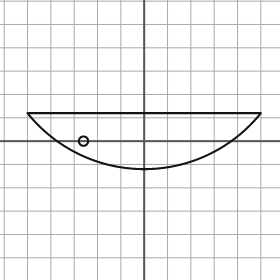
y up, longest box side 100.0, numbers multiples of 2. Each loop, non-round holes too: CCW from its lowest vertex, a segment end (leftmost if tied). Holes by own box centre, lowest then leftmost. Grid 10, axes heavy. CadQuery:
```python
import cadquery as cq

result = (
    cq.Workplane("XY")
    .moveTo(-50.0, 12.0)
    .threePointArc((0.0, -12.0), (50.0, 12.0))
    .close()
    .moveTo(-26.0, 0.0)
    .circle(2.0)
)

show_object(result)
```